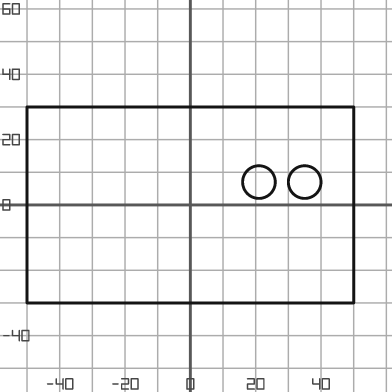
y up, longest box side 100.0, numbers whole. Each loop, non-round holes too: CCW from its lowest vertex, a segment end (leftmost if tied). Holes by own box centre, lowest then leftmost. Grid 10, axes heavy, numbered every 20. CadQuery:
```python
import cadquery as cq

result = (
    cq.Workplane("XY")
    .moveTo(-50.0, -30.0)
    .lineTo(50.0, -30.0)
    .lineTo(50.0, 30.0)
    .lineTo(-50.0, 30.0)
    .close()
    .moveTo(21.0, 7.0)
    .circle(5.0)
    .moveTo(35.0, 7.0)
    .circle(5.0)
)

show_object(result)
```